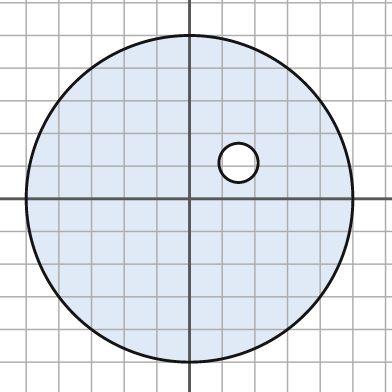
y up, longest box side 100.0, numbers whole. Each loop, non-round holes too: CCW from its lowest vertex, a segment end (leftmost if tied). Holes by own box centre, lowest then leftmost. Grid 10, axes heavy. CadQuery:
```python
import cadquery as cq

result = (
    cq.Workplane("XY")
    .moveTo(0.0, 0.0)
    .circle(50.0)
    .moveTo(15.0, 11.0)
    .circle(6.0)
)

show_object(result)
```